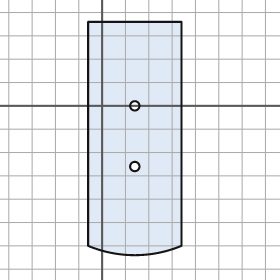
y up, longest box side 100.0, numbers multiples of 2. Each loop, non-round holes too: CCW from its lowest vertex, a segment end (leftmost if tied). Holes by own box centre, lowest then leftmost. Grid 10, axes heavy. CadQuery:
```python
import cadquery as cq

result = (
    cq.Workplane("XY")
    .moveTo(-6.0, -60.0)
    .threePointArc((14.0, -64.0), (34.0, -60.0))
    .lineTo(34.0, 36.0)
    .lineTo(-6.0, 36.0)
    .close()
    .moveTo(14.0, -26.0)
    .circle(2.0)
    .moveTo(14.0, 0.0)
    .circle(2.0)
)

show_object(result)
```